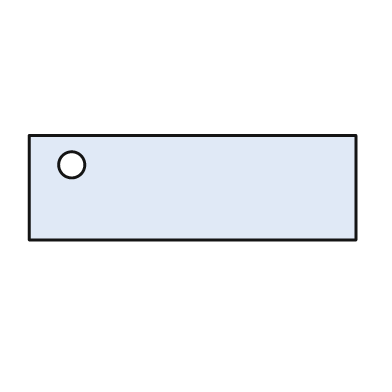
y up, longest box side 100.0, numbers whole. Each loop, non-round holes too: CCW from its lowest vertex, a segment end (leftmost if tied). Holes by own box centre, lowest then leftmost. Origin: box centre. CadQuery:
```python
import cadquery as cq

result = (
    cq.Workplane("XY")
    .moveTo(-50.0, -16.0)
    .lineTo(50.0, -16.0)
    .lineTo(50.0, 16.0)
    .lineTo(-50.0, 16.0)
    .close()
    .moveTo(-37.0, 7.0)
    .circle(4.0)
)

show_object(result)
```